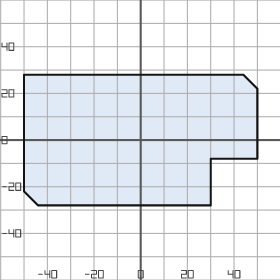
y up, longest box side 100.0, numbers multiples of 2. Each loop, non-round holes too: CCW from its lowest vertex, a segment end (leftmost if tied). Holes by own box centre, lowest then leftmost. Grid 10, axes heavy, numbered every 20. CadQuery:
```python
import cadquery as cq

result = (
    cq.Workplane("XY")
    .moveTo(-44.0, -28.0)
    .lineTo(30.0, -28.0)
    .lineTo(30.0, -8.0)
    .lineTo(50.0, -8.0)
    .lineTo(50.0, 22.0)
    .lineTo(44.0, 28.0)
    .lineTo(-50.0, 28.0)
    .lineTo(-50.0, -22.0)
    .close()
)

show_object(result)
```